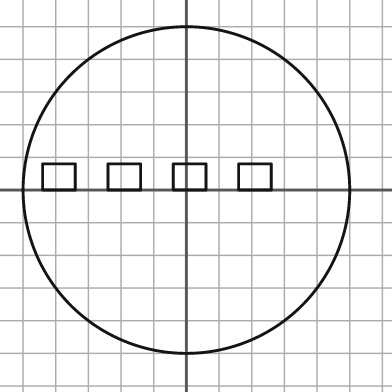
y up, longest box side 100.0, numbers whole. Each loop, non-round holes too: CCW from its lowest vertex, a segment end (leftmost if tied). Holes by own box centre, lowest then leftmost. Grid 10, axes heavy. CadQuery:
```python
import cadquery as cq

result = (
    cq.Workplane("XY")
    .moveTo(0.0, 0.0)
    .circle(50.0)
    .moveTo(-44.0, 0.0)
    .lineTo(-34.0, 0.0)
    .lineTo(-34.0, 8.0)
    .lineTo(-44.0, 8.0)
    .close()
    .moveTo(-24.0, 0.0)
    .lineTo(-14.0, 0.0)
    .lineTo(-14.0, 8.0)
    .lineTo(-24.0, 8.0)
    .close()
    .moveTo(-4.0, 0.0)
    .lineTo(6.0, 0.0)
    .lineTo(6.0, 8.0)
    .lineTo(-4.0, 8.0)
    .close()
    .moveTo(16.0, 0.0)
    .lineTo(26.0, 0.0)
    .lineTo(26.0, 8.0)
    .lineTo(16.0, 8.0)
    .close()
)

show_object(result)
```